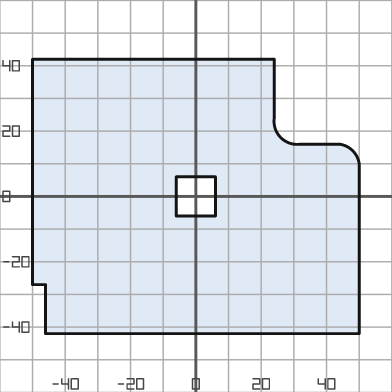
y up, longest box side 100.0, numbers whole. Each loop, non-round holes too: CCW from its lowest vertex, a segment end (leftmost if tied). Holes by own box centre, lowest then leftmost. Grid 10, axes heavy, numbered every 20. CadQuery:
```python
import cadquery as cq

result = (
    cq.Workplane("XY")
    .moveTo(-46.0, -42.0)
    .lineTo(50.0, -42.0)
    .lineTo(50.0, 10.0)
    .threePointArc((48.0, 14.0), (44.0, 16.0))
    .lineTo(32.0, 16.0)
    .threePointArc((26.0, 18.0), (24.0, 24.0))
    .lineTo(24.0, 42.0)
    .lineTo(-50.0, 42.0)
    .lineTo(-50.0, -27.0)
    .lineTo(-46.0, -27.0)
    .close()
    .moveTo(-6.0, -6.0)
    .lineTo(6.0, -6.0)
    .lineTo(6.0, 6.0)
    .lineTo(-6.0, 6.0)
    .close()
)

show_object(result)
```